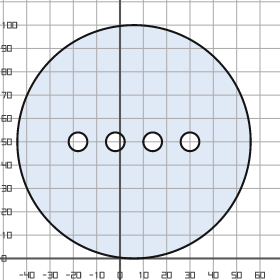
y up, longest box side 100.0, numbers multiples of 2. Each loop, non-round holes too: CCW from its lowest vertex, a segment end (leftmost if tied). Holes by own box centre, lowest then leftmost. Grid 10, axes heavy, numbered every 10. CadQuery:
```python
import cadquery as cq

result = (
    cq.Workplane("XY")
    .moveTo(6.0, 50.0)
    .circle(50.0)
    .moveTo(-18.0, 50.0)
    .circle(4.0)
    .moveTo(-2.0, 50.0)
    .circle(4.0)
    .moveTo(14.0, 50.0)
    .circle(4.0)
    .moveTo(30.0, 50.0)
    .circle(4.0)
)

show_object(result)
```